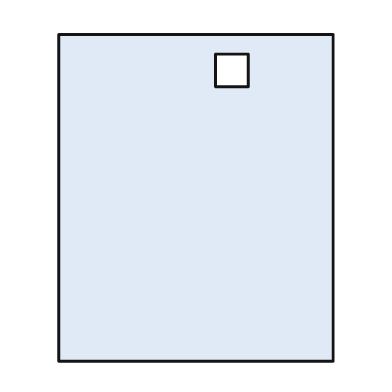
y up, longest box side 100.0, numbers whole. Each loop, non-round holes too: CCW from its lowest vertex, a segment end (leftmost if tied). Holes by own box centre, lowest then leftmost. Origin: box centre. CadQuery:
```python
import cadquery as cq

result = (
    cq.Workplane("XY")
    .moveTo(-42.0, -50.0)
    .lineTo(42.0, -50.0)
    .lineTo(42.0, 50.0)
    .lineTo(-42.0, 50.0)
    .close()
    .moveTo(6.0, 34.0)
    .lineTo(16.0, 34.0)
    .lineTo(16.0, 44.0)
    .lineTo(6.0, 44.0)
    .close()
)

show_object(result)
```